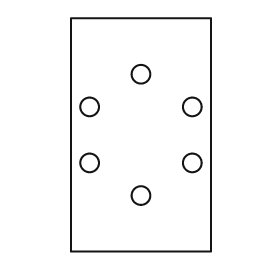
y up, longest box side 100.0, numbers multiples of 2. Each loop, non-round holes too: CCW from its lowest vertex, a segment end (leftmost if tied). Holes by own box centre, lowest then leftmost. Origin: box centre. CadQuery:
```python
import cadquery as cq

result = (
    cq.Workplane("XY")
    .moveTo(-30.0, -50.0)
    .lineTo(30.0, -50.0)
    .lineTo(30.0, 50.0)
    .lineTo(-30.0, 50.0)
    .close()
    .moveTo(0.0, -26.0)
    .circle(4.0)
    .moveTo(-22.0, -12.0)
    .circle(4.0)
    .moveTo(22.0, -12.0)
    .circle(4.0)
    .moveTo(-22.0, 12.0)
    .circle(4.0)
    .moveTo(22.0, 12.0)
    .circle(4.0)
    .moveTo(0.0, 26.0)
    .circle(4.0)
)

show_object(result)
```